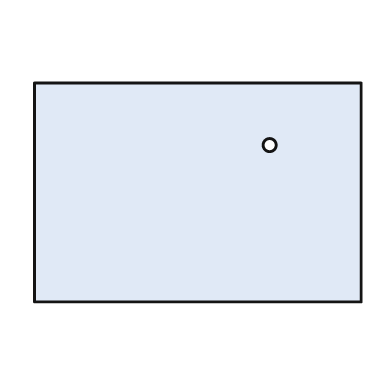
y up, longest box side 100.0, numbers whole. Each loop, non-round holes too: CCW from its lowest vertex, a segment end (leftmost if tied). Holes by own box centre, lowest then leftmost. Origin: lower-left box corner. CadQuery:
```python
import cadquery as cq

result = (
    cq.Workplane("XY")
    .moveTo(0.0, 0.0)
    .lineTo(100.0, 0.0)
    .lineTo(100.0, 67.0)
    .lineTo(0.0, 67.0)
    .close()
    .moveTo(72.0, 48.0)
    .circle(2.0)
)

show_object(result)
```